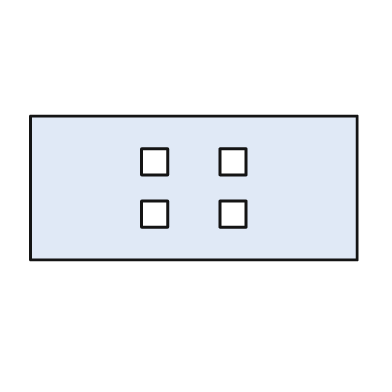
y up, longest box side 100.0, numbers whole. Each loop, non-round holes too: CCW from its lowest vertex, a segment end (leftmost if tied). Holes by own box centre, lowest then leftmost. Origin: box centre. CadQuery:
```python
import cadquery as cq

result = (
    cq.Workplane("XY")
    .moveTo(-50.0, -22.0)
    .lineTo(50.0, -22.0)
    .lineTo(50.0, 22.0)
    .lineTo(-50.0, 22.0)
    .close()
    .moveTo(-16.0, -12.0)
    .lineTo(-8.0, -12.0)
    .lineTo(-8.0, -4.0)
    .lineTo(-16.0, -4.0)
    .close()
    .moveTo(8.0, -12.0)
    .lineTo(16.0, -12.0)
    .lineTo(16.0, -4.0)
    .lineTo(8.0, -4.0)
    .close()
    .moveTo(-16.0, 4.0)
    .lineTo(-8.0, 4.0)
    .lineTo(-8.0, 12.0)
    .lineTo(-16.0, 12.0)
    .close()
    .moveTo(8.0, 4.0)
    .lineTo(16.0, 4.0)
    .lineTo(16.0, 12.0)
    .lineTo(8.0, 12.0)
    .close()
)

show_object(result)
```